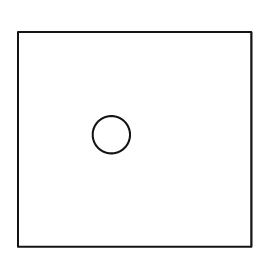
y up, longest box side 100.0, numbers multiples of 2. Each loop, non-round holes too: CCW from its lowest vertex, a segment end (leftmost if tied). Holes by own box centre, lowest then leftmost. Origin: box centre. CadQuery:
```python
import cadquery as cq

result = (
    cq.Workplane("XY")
    .moveTo(-50.0, -46.0)
    .lineTo(50.0, -46.0)
    .lineTo(50.0, 46.0)
    .lineTo(-50.0, 46.0)
    .close()
    .moveTo(-10.0, 2.0)
    .circle(8.0)
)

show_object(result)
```